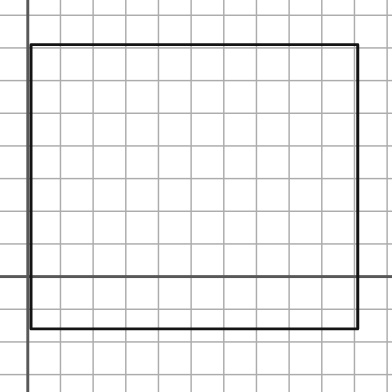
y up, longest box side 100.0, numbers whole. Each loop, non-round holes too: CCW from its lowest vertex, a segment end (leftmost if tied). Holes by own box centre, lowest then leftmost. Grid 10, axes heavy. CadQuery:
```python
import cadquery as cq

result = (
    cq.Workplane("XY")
    .moveTo(1.0, -16.0)
    .lineTo(101.0, -16.0)
    .lineTo(101.0, 71.0)
    .lineTo(1.0, 71.0)
    .close()
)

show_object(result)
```